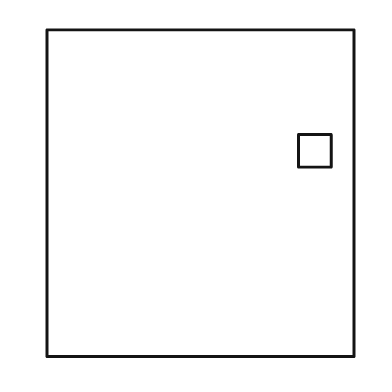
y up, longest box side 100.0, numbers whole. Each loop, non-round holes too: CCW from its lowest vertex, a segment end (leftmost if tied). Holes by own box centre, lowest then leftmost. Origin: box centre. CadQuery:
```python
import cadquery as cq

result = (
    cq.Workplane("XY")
    .moveTo(-47.0, -50.0)
    .lineTo(47.0, -50.0)
    .lineTo(47.0, 50.0)
    .lineTo(-47.0, 50.0)
    .close()
    .moveTo(30.0, 8.0)
    .lineTo(40.0, 8.0)
    .lineTo(40.0, 18.0)
    .lineTo(30.0, 18.0)
    .close()
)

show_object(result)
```